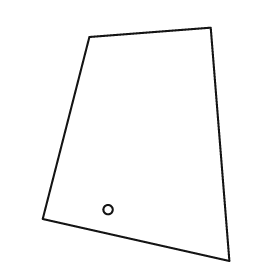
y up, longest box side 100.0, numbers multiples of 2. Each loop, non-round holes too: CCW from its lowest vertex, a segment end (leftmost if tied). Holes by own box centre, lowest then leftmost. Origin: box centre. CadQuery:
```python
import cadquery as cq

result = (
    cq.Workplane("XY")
    .moveTo(40.0, -50.0)
    .lineTo(32.0, 50.0)
    .lineTo(-20.0, 46.0)
    .lineTo(-40.0, -32.0)
    .close()
    .moveTo(-12.0, -28.0)
    .circle(2.0)
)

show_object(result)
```